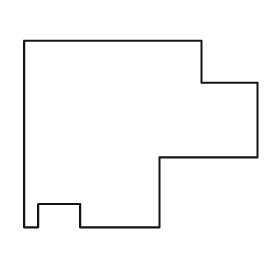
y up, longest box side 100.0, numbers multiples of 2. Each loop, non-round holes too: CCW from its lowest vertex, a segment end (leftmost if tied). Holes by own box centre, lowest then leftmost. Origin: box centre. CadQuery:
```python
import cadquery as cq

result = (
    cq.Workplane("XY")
    .moveTo(-50.0, -40.0)
    .lineTo(-44.0, -40.0)
    .lineTo(-44.0, -30.0)
    .lineTo(-26.0, -30.0)
    .lineTo(-26.0, -40.0)
    .lineTo(8.0, -40.0)
    .lineTo(8.0, -10.0)
    .lineTo(50.0, -10.0)
    .lineTo(50.0, 22.0)
    .lineTo(26.0, 22.0)
    .lineTo(26.0, 40.0)
    .lineTo(-50.0, 40.0)
    .close()
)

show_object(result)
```